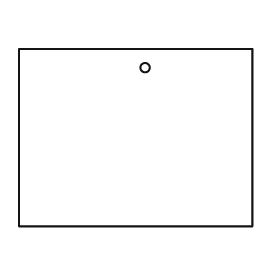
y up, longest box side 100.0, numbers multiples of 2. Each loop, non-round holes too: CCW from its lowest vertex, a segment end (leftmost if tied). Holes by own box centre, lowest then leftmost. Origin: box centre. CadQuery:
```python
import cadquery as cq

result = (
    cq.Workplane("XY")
    .moveTo(-50.0, -38.0)
    .lineTo(50.0, -38.0)
    .lineTo(50.0, 38.0)
    .lineTo(-50.0, 38.0)
    .close()
    .moveTo(4.0, 30.0)
    .circle(2.0)
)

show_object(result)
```